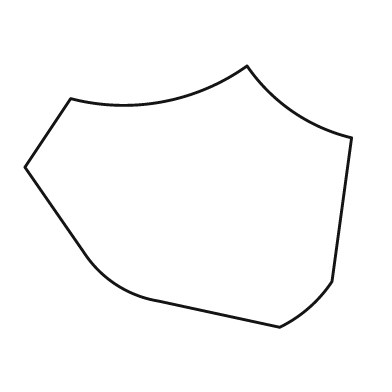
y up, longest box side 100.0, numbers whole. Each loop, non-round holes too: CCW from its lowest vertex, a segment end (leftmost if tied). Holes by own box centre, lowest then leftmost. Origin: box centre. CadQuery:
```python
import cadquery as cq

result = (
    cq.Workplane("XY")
    .moveTo(28.0, -40.0)
    .threePointArc((37.0, -34.0), (44.0, -26.0))
    .lineTo(50.0, 18.0)
    .threePointArc((32.0, 26.0), (18.0, 40.0))
    .threePointArc((-8.0, 29.0), (-36.0, 30.0))
    .lineTo(-50.0, 9.0)
    .lineTo(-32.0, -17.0)
    .threePointArc((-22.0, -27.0), (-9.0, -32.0))
    .close()
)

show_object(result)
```